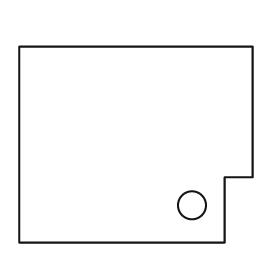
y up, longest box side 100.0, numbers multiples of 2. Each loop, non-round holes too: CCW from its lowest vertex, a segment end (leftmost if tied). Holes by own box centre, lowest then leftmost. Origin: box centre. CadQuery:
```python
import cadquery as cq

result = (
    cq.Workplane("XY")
    .moveTo(-50.0, -42.0)
    .lineTo(38.0, -42.0)
    .lineTo(38.0, -14.0)
    .lineTo(50.0, -14.0)
    .lineTo(50.0, 42.0)
    .lineTo(-50.0, 42.0)
    .close()
    .moveTo(24.0, -26.0)
    .circle(6.0)
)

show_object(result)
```